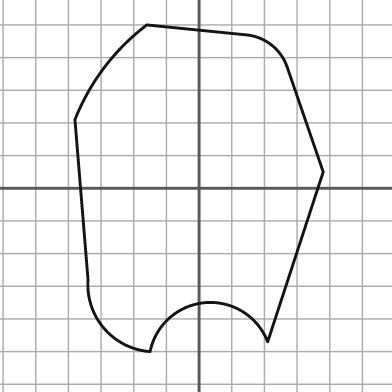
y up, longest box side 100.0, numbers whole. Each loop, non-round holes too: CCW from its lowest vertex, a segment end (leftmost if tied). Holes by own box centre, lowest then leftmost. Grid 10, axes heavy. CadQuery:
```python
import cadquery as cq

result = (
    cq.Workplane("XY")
    .moveTo(-15.0, -50.0)
    .threePointArc((2.0, -35.0), (21.0, -47.0))
    .lineTo(38.0, 5.0)
    .lineTo(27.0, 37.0)
    .threePointArc((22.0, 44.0), (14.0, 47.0))
    .lineTo(-16.0, 50.0)
    .threePointArc((-29.0, 37.0), (-38.0, 21.0))
    .lineTo(-34.0, -28.0)
    .threePointArc((-29.0, -43.0), (-15.0, -50.0))
    .close()
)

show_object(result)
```